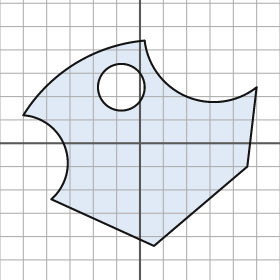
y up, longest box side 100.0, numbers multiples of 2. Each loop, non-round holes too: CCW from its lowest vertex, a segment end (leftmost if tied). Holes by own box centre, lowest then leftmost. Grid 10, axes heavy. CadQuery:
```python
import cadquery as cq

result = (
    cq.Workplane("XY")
    .moveTo(6.0, -44.0)
    .lineTo(46.0, -10.0)
    .lineTo(50.0, 24.0)
    .threePointArc((20.0, 20.0), (2.0, 44.0))
    .threePointArc((-28.0, 34.0), (-50.0, 12.0))
    .threePointArc((-32.0, -2.0), (-38.0, -24.0))
    .close()
    .moveTo(-8.0, 24.0)
    .circle(10.0)
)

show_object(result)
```